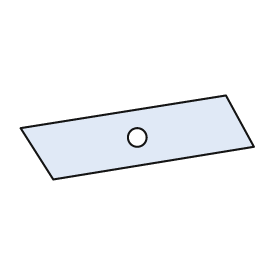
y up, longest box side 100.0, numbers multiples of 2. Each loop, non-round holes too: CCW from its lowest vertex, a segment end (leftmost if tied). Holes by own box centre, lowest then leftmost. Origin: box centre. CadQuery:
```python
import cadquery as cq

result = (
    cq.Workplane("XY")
    .moveTo(-36.0, -18.0)
    .lineTo(50.0, -4.0)
    .lineTo(38.0, 18.0)
    .lineTo(-50.0, 4.0)
    .close()
    .moveTo(0.0, 0.0)
    .circle(4.0)
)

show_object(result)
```